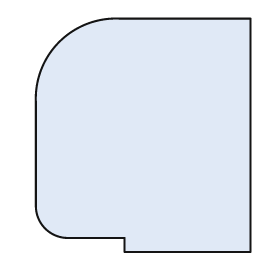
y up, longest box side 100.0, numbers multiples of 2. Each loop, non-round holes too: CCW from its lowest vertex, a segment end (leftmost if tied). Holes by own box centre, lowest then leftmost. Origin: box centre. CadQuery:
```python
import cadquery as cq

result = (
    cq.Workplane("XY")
    .moveTo(-8.0, -50.0)
    .lineTo(46.0, -50.0)
    .lineTo(46.0, 50.0)
    .lineTo(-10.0, 50.0)
    .threePointArc((-36.0, 40.0), (-46.0, 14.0))
    .lineTo(-46.0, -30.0)
    .threePointArc((-42.0, -40.0), (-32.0, -44.0))
    .lineTo(-8.0, -44.0)
    .close()
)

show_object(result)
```